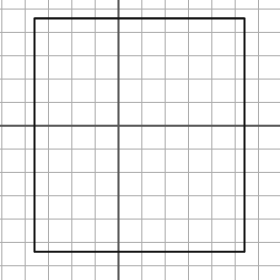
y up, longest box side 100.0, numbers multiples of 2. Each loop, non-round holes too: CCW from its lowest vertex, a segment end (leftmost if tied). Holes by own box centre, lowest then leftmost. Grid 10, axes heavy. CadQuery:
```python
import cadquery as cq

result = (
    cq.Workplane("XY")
    .moveTo(-36.0, -54.0)
    .lineTo(54.0, -54.0)
    .lineTo(54.0, 46.0)
    .lineTo(-36.0, 46.0)
    .close()
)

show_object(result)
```